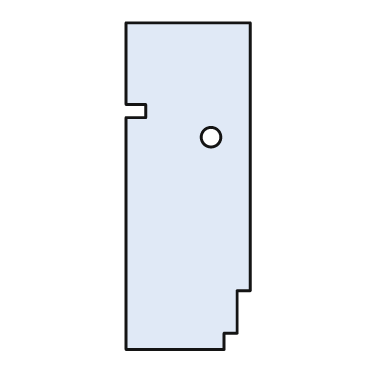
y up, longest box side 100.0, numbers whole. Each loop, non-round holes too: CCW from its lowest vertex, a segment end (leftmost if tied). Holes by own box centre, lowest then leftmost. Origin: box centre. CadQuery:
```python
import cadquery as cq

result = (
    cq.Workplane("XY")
    .moveTo(-19.0, -50.0)
    .lineTo(11.0, -50.0)
    .lineTo(11.0, -45.0)
    .lineTo(15.0, -45.0)
    .lineTo(15.0, -32.0)
    .lineTo(19.0, -32.0)
    .lineTo(19.0, 50.0)
    .lineTo(-19.0, 50.0)
    .lineTo(-19.0, 25.0)
    .lineTo(-13.0, 25.0)
    .lineTo(-13.0, 21.0)
    .lineTo(-19.0, 21.0)
    .close()
    .moveTo(7.0, 15.0)
    .circle(3.0)
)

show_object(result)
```